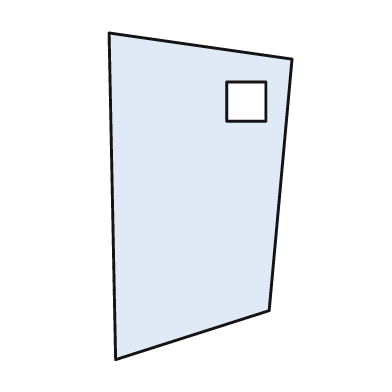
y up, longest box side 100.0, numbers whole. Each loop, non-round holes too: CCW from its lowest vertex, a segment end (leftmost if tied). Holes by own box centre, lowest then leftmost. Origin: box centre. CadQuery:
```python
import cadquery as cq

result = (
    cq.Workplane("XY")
    .moveTo(-26.0, -50.0)
    .lineTo(21.0, -35.0)
    .lineTo(28.0, 42.0)
    .lineTo(-28.0, 50.0)
    .close()
    .moveTo(8.0, 23.0)
    .lineTo(20.0, 23.0)
    .lineTo(20.0, 35.0)
    .lineTo(8.0, 35.0)
    .close()
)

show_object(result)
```